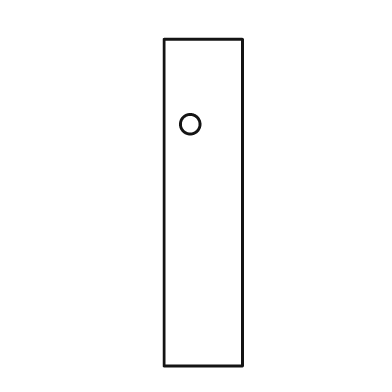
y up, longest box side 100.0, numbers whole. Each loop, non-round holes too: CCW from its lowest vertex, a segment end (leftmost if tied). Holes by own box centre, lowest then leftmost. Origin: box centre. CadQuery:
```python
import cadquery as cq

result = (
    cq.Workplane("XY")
    .moveTo(-12.0, -50.0)
    .lineTo(12.0, -50.0)
    .lineTo(12.0, 50.0)
    .lineTo(-12.0, 50.0)
    .close()
    .moveTo(-4.0, 24.0)
    .circle(3.0)
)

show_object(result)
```